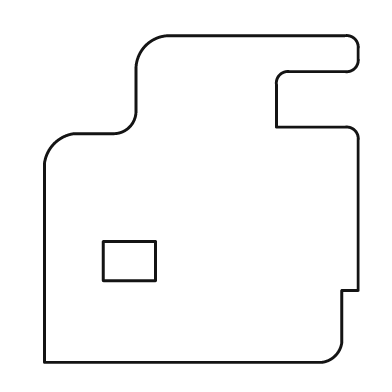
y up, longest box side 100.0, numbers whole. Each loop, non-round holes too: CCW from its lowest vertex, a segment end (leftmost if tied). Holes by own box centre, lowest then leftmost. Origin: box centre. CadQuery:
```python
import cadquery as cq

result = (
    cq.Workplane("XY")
    .moveTo(-48.0, -50.0)
    .lineTo(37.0, -50.0)
    .threePointArc((41.0, -48.0), (43.0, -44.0))
    .lineTo(43.0, -28.0)
    .lineTo(48.0, -28.0)
    .lineTo(48.0, 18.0)
    .threePointArc((47.0, 21.0), (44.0, 22.0))
    .lineTo(23.0, 22.0)
    .lineTo(23.0, 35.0)
    .threePointArc((24.0, 38.0), (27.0, 39.0))
    .lineTo(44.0, 39.0)
    .threePointArc((47.0, 40.0), (48.0, 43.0))
    .lineTo(48.0, 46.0)
    .threePointArc((47.0, 49.0), (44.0, 50.0))
    .lineTo(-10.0, 50.0)
    .threePointArc((-17.0, 47.0), (-20.0, 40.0))
    .lineTo(-20.0, 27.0)
    .threePointArc((-22.0, 22.0), (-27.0, 20.0))
    .lineTo(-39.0, 20.0)
    .threePointArc((-45.0, 17.0), (-48.0, 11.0))
    .close()
    .moveTo(-30.0, -25.0)
    .lineTo(-14.0, -25.0)
    .lineTo(-14.0, -13.0)
    .lineTo(-30.0, -13.0)
    .close()
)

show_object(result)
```